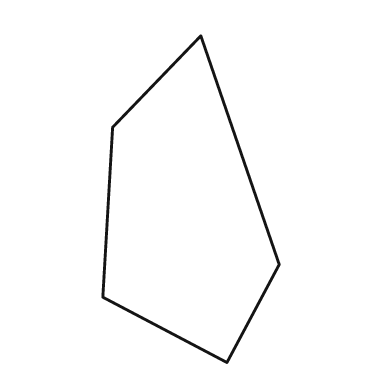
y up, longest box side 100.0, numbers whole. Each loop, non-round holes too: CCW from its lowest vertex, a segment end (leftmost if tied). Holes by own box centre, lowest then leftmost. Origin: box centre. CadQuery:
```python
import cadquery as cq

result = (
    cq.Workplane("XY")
    .moveTo(11.0, -50.0)
    .lineTo(27.0, -20.0)
    .lineTo(3.0, 50.0)
    .lineTo(-24.0, 22.0)
    .lineTo(-27.0, -30.0)
    .close()
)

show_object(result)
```